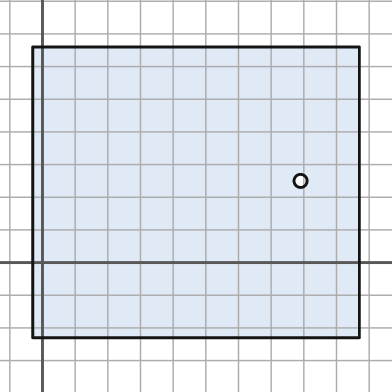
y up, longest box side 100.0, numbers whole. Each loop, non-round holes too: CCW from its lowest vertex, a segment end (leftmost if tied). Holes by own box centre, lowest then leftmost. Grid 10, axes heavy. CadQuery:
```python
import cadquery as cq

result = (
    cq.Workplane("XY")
    .moveTo(-3.0, -23.0)
    .lineTo(97.0, -23.0)
    .lineTo(97.0, 66.0)
    .lineTo(-3.0, 66.0)
    .close()
    .moveTo(79.0, 25.0)
    .circle(2.0)
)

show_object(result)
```